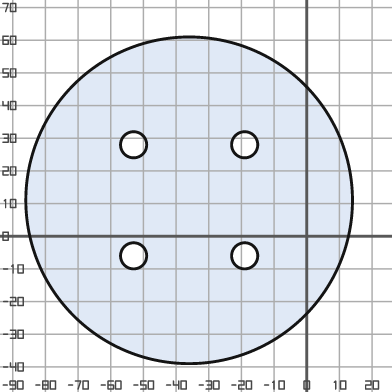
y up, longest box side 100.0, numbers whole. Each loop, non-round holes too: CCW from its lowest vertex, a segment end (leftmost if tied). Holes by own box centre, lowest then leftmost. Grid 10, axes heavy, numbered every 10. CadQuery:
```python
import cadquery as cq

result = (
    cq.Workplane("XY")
    .moveTo(-36.0, 11.0)
    .circle(50.0)
    .moveTo(-53.0, -6.0)
    .circle(4.0)
    .moveTo(-19.0, -6.0)
    .circle(4.0)
    .moveTo(-53.0, 28.0)
    .circle(4.0)
    .moveTo(-19.0, 28.0)
    .circle(4.0)
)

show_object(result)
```